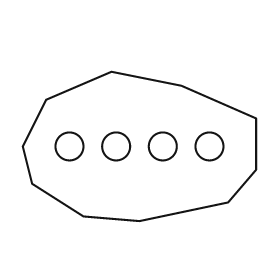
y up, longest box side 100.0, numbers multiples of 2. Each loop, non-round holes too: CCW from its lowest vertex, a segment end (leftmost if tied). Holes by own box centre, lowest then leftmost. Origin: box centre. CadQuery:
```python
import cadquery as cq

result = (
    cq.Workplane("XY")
    .moveTo(0.0, -32.0)
    .lineTo(38.0, -24.0)
    .lineTo(50.0, -10.0)
    .lineTo(50.0, 12.0)
    .lineTo(18.0, 26.0)
    .lineTo(-12.0, 32.0)
    .lineTo(-40.0, 20.0)
    .lineTo(-50.0, 0.0)
    .lineTo(-46.0, -16.0)
    .lineTo(-24.0, -30.0)
    .close()
    .moveTo(-30.0, 0.0)
    .circle(6.0)
    .moveTo(-10.0, 0.0)
    .circle(6.0)
    .moveTo(10.0, 0.0)
    .circle(6.0)
    .moveTo(30.0, 0.0)
    .circle(6.0)
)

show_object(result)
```